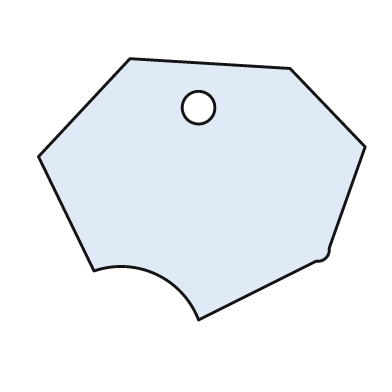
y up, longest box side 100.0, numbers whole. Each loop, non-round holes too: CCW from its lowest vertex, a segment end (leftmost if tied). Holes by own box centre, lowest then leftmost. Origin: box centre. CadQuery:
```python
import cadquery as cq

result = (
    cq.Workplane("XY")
    .moveTo(-1.0, -40.0)
    .lineTo(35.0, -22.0)
    .threePointArc((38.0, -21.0), (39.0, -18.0))
    .lineTo(50.0, 13.0)
    .lineTo(27.0, 37.0)
    .lineTo(-22.0, 40.0)
    .lineTo(-50.0, 10.0)
    .lineTo(-33.0, -25.0)
    .threePointArc((-14.0, -26.0), (-1.0, -40.0))
    .close()
    .moveTo(-1.0, 25.0)
    .circle(5.0)
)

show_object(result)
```